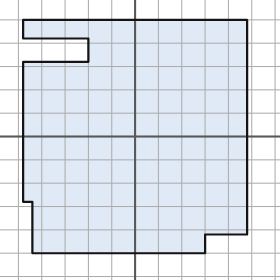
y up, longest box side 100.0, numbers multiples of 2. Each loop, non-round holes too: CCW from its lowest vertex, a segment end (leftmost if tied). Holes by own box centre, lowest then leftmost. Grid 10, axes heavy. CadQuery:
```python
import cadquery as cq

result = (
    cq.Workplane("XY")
    .moveTo(-44.0, -50.0)
    .lineTo(30.0, -50.0)
    .lineTo(30.0, -42.0)
    .lineTo(48.0, -42.0)
    .lineTo(48.0, 50.0)
    .lineTo(-48.0, 50.0)
    .lineTo(-48.0, 42.0)
    .lineTo(-20.0, 42.0)
    .lineTo(-20.0, 32.0)
    .lineTo(-48.0, 32.0)
    .lineTo(-48.0, -28.0)
    .lineTo(-44.0, -28.0)
    .close()
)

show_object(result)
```